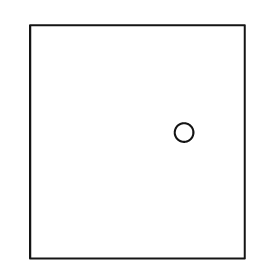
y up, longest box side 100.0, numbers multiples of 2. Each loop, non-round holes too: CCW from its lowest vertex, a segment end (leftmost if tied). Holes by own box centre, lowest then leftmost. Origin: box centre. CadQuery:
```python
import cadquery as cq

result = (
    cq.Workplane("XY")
    .moveTo(-46.0, -50.0)
    .lineTo(46.0, -50.0)
    .lineTo(46.0, 50.0)
    .lineTo(-46.0, 50.0)
    .close()
    .moveTo(20.0, 4.0)
    .circle(4.0)
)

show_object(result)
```